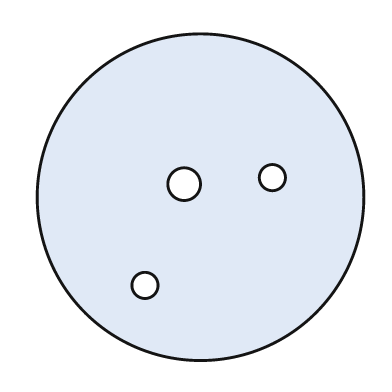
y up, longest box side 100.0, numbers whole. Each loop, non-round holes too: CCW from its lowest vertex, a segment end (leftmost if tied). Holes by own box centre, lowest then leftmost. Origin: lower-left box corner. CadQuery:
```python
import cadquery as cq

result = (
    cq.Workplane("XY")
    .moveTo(50.0, 50.0)
    .circle(50.0)
    .moveTo(33.0, 23.0)
    .circle(4.0)
    .moveTo(45.0, 54.0)
    .circle(5.0)
    .moveTo(72.0, 56.0)
    .circle(4.0)
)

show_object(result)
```